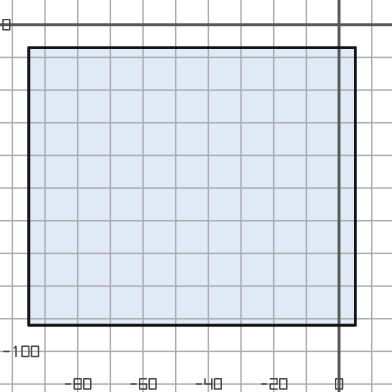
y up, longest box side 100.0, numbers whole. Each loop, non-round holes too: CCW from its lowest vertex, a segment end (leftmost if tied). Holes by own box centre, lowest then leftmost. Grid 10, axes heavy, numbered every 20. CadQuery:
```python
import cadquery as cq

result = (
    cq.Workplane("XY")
    .moveTo(-95.0, -92.0)
    .lineTo(5.0, -92.0)
    .lineTo(5.0, -7.0)
    .lineTo(-95.0, -7.0)
    .close()
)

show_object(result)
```